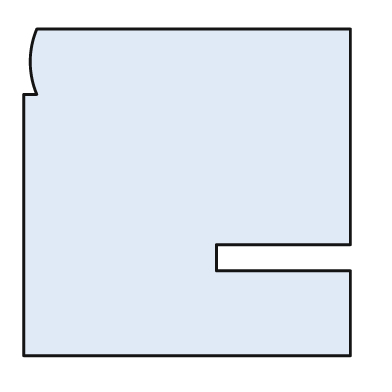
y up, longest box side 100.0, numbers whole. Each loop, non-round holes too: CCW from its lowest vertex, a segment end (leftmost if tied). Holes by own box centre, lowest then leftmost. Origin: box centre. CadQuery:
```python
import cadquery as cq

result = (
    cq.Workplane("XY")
    .moveTo(-50.0, -50.0)
    .lineTo(50.0, -50.0)
    .lineTo(50.0, -24.0)
    .lineTo(9.0, -24.0)
    .lineTo(9.0, -16.0)
    .lineTo(50.0, -16.0)
    .lineTo(50.0, 50.0)
    .lineTo(-46.0, 50.0)
    .threePointArc((-48.0, 40.0), (-46.0, 30.0))
    .lineTo(-50.0, 30.0)
    .close()
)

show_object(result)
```